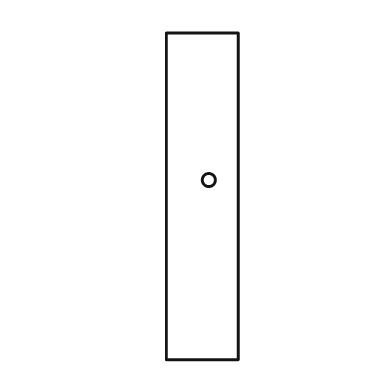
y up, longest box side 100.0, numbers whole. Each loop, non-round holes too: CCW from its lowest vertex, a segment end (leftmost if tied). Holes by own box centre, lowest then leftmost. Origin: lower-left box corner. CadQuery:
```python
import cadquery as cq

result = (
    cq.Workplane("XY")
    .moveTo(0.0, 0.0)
    .lineTo(22.0, 0.0)
    .lineTo(22.0, 100.0)
    .lineTo(0.0, 100.0)
    .close()
    .moveTo(13.0, 55.0)
    .circle(2.0)
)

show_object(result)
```